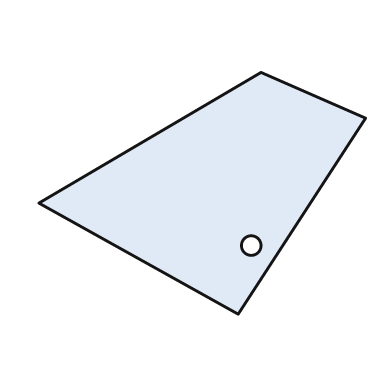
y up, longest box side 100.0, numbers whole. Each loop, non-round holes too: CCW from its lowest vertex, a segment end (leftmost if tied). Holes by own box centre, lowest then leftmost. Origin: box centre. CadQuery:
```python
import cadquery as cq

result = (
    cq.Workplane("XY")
    .moveTo(11.0, -37.0)
    .lineTo(50.0, 23.0)
    .lineTo(18.0, 37.0)
    .lineTo(-50.0, -3.0)
    .close()
    .moveTo(15.0, -16.0)
    .circle(3.0)
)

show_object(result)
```